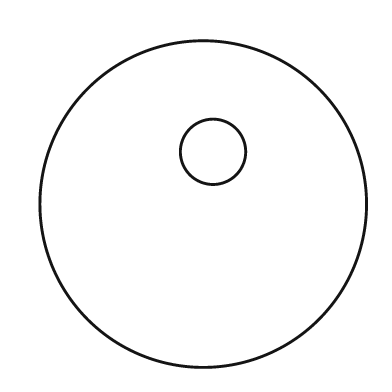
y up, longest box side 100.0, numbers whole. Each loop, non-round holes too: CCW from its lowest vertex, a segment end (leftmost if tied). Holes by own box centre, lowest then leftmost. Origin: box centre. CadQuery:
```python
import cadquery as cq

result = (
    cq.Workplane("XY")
    .moveTo(0.0, 0.0)
    .circle(50.0)
    .moveTo(3.0, 16.0)
    .circle(10.0)
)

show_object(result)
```